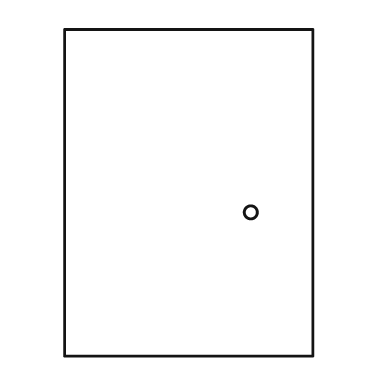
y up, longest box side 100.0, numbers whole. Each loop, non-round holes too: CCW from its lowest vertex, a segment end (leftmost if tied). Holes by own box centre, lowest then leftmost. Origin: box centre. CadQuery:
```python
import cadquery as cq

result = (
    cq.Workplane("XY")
    .moveTo(-38.0, -50.0)
    .lineTo(38.0, -50.0)
    .lineTo(38.0, 50.0)
    .lineTo(-38.0, 50.0)
    .close()
    .moveTo(19.0, -6.0)
    .circle(2.0)
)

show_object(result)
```